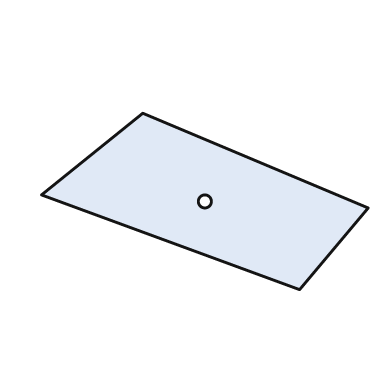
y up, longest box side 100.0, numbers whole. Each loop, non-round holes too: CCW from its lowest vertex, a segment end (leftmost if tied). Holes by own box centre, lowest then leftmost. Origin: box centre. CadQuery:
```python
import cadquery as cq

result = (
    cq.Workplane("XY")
    .moveTo(29.0, -27.0)
    .lineTo(50.0, -2.0)
    .lineTo(-19.0, 27.0)
    .lineTo(-50.0, 2.0)
    .close()
    .moveTo(0.0, 0.0)
    .circle(2.0)
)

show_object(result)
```